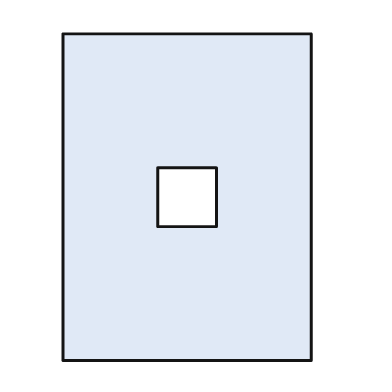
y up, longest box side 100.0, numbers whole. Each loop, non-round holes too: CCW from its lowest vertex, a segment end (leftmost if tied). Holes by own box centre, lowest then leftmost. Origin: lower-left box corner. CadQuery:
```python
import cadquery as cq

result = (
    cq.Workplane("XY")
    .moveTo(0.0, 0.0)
    .lineTo(76.0, 0.0)
    .lineTo(76.0, 100.0)
    .lineTo(0.0, 100.0)
    .close()
    .moveTo(29.0, 41.0)
    .lineTo(47.0, 41.0)
    .lineTo(47.0, 59.0)
    .lineTo(29.0, 59.0)
    .close()
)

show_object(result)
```